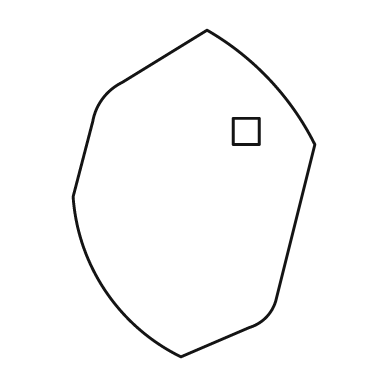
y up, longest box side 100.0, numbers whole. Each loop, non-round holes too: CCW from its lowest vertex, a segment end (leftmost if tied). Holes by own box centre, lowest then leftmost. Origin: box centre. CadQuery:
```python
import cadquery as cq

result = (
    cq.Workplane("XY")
    .moveTo(-4.0, -50.0)
    .lineTo(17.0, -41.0)
    .threePointArc((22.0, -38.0), (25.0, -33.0))
    .lineTo(37.0, 15.0)
    .threePointArc((23.0, 35.0), (4.0, 50.0))
    .lineTo(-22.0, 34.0)
    .threePointArc((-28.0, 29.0), (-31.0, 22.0))
    .lineTo(-37.0, -1.0)
    .threePointArc((-27.0, -30.0), (-4.0, -50.0))
    .close()
    .moveTo(12.0, 15.0)
    .lineTo(20.0, 15.0)
    .lineTo(20.0, 23.0)
    .lineTo(12.0, 23.0)
    .close()
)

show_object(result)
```